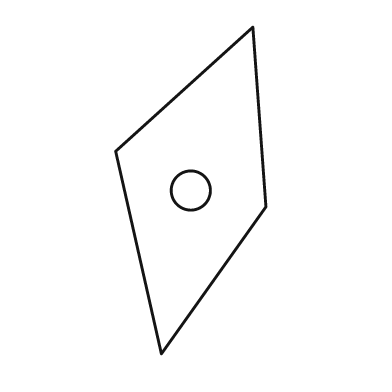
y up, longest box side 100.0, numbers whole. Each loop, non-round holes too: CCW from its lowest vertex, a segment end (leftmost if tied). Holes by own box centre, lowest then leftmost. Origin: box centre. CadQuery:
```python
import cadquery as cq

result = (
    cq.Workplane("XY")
    .moveTo(-9.0, -50.0)
    .lineTo(23.0, -5.0)
    .lineTo(19.0, 50.0)
    .lineTo(-23.0, 12.0)
    .close()
    .moveTo(0.0, 0.0)
    .circle(6.0)
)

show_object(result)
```